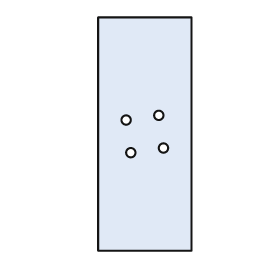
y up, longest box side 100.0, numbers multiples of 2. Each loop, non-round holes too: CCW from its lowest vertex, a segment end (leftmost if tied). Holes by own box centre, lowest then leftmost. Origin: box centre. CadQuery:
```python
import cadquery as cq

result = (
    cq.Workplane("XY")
    .moveTo(-20.0, -50.0)
    .lineTo(20.0, -50.0)
    .lineTo(20.0, 50.0)
    .lineTo(-20.0, 50.0)
    .close()
    .moveTo(-6.0, -8.0)
    .circle(2.0)
    .moveTo(8.0, -6.0)
    .circle(2.0)
    .moveTo(-8.0, 6.0)
    .circle(2.0)
    .moveTo(6.0, 8.0)
    .circle(2.0)
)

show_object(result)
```